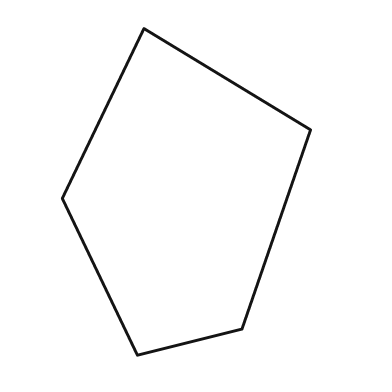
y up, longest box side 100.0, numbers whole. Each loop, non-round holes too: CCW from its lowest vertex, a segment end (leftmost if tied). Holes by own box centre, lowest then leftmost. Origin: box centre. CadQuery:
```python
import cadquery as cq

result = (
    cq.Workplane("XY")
    .moveTo(-15.0, -50.0)
    .lineTo(17.0, -42.0)
    .lineTo(38.0, 19.0)
    .lineTo(-13.0, 50.0)
    .lineTo(-38.0, -2.0)
    .close()
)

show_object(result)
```